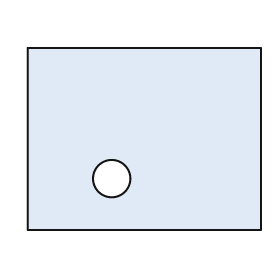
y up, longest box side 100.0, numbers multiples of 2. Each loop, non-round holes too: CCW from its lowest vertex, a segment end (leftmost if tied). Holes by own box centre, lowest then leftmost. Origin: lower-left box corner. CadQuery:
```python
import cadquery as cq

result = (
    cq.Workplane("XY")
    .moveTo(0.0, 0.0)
    .lineTo(100.0, 0.0)
    .lineTo(100.0, 78.0)
    .lineTo(0.0, 78.0)
    .close()
    .moveTo(36.0, 22.0)
    .circle(8.0)
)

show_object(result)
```